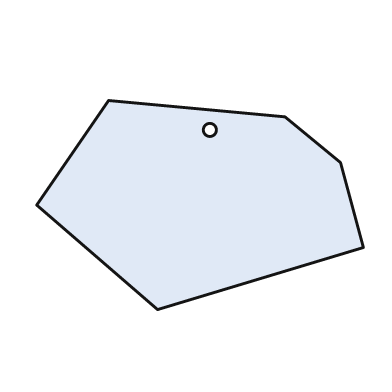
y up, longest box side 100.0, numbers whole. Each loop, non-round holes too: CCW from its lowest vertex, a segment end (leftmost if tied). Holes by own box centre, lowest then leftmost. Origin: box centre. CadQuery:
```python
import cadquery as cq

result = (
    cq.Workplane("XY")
    .moveTo(-13.0, -32.0)
    .lineTo(50.0, -13.0)
    .lineTo(43.0, 13.0)
    .lineTo(26.0, 27.0)
    .lineTo(-28.0, 32.0)
    .lineTo(-50.0, 0.0)
    .close()
    .moveTo(3.0, 23.0)
    .circle(2.0)
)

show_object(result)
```